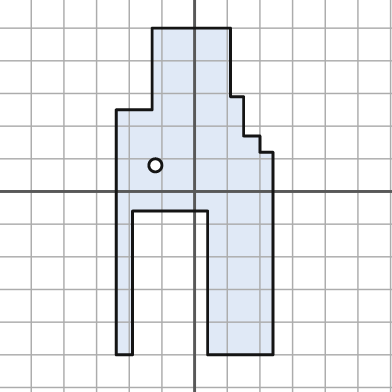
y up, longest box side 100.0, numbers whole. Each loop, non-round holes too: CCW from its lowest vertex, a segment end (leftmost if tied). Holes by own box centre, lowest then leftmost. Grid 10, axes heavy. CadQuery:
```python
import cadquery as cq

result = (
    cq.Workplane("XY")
    .moveTo(-24.0, -50.0)
    .lineTo(-19.0, -50.0)
    .lineTo(-19.0, -6.0)
    .lineTo(4.0, -6.0)
    .lineTo(4.0, -50.0)
    .lineTo(24.0, -50.0)
    .lineTo(24.0, 12.0)
    .lineTo(20.0, 12.0)
    .lineTo(20.0, 17.0)
    .lineTo(15.0, 17.0)
    .lineTo(15.0, 29.0)
    .lineTo(11.0, 29.0)
    .lineTo(11.0, 50.0)
    .lineTo(-13.0, 50.0)
    .lineTo(-13.0, 25.0)
    .lineTo(-24.0, 25.0)
    .close()
    .moveTo(-12.0, 8.0)
    .circle(2.0)
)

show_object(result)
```